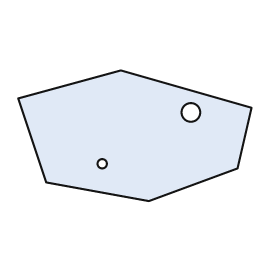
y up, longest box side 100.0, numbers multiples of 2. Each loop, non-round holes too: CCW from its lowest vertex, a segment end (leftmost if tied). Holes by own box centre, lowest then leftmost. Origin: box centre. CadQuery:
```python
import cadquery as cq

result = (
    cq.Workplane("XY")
    .moveTo(6.0, -28.0)
    .lineTo(44.0, -14.0)
    .lineTo(50.0, 12.0)
    .lineTo(-6.0, 28.0)
    .lineTo(-50.0, 16.0)
    .lineTo(-38.0, -20.0)
    .close()
    .moveTo(-14.0, -12.0)
    .circle(2.0)
    .moveTo(24.0, 10.0)
    .circle(4.0)
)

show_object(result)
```